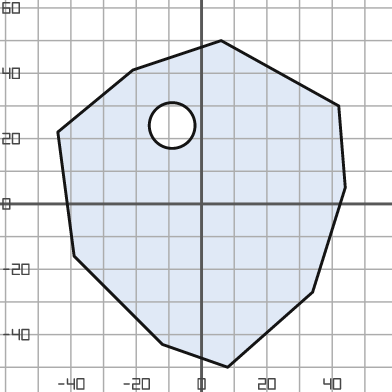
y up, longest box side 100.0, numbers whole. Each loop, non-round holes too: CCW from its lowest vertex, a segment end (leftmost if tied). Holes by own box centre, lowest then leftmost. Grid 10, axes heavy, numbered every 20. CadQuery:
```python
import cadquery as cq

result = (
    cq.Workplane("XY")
    .moveTo(8.0, -50.0)
    .lineTo(34.0, -27.0)
    .lineTo(44.0, 5.0)
    .lineTo(42.0, 30.0)
    .lineTo(6.0, 50.0)
    .lineTo(-21.0, 41.0)
    .lineTo(-44.0, 22.0)
    .lineTo(-39.0, -16.0)
    .lineTo(-12.0, -43.0)
    .close()
    .moveTo(-9.0, 24.0)
    .circle(7.0)
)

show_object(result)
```